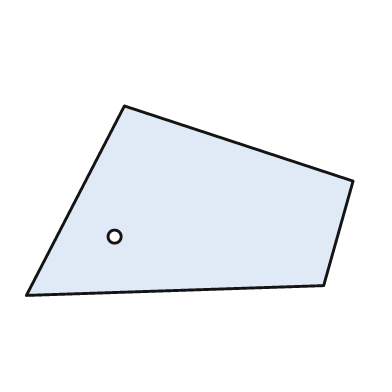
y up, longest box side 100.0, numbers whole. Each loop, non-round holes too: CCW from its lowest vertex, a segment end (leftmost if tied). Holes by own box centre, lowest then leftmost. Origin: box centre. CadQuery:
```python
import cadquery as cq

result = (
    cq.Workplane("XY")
    .moveTo(-50.0, -29.0)
    .lineTo(41.0, -26.0)
    .lineTo(50.0, 6.0)
    .lineTo(-20.0, 29.0)
    .close()
    .moveTo(-23.0, -11.0)
    .circle(2.0)
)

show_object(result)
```